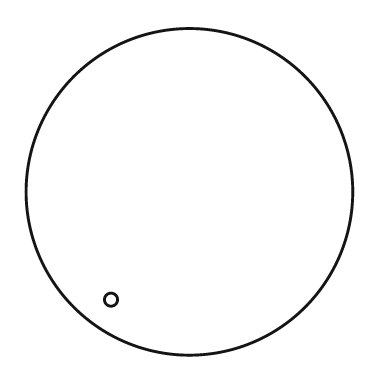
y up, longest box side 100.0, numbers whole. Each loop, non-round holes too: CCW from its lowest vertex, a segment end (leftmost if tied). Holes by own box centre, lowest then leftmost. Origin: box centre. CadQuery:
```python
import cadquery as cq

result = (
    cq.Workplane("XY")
    .moveTo(0.0, 0.0)
    .circle(50.0)
    .moveTo(-24.0, -33.0)
    .circle(2.0)
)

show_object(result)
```